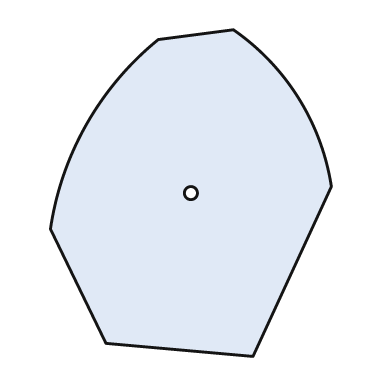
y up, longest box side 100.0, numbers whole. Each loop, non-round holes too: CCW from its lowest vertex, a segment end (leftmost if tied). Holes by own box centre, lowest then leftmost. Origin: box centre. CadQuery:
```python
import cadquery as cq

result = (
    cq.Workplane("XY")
    .moveTo(19.0, -50.0)
    .lineTo(43.0, 2.0)
    .threePointArc((33.0, 29.0), (13.0, 50.0))
    .lineTo(-10.0, 47.0)
    .threePointArc((-32.0, 21.0), (-43.0, -11.0))
    .lineTo(-26.0, -46.0)
    .close()
    .moveTo(0.0, 0.0)
    .circle(2.0)
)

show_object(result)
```